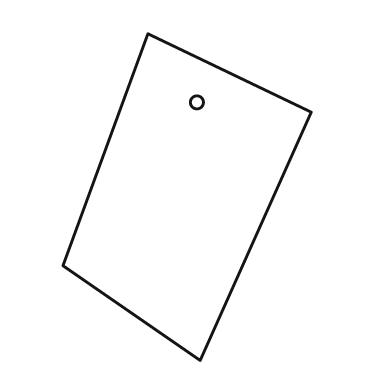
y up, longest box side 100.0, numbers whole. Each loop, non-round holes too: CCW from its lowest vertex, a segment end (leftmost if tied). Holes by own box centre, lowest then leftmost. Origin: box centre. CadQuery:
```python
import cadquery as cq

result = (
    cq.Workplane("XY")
    .moveTo(4.0, -50.0)
    .lineTo(38.0, 26.0)
    .lineTo(-12.0, 50.0)
    .lineTo(-38.0, -21.0)
    .close()
    .moveTo(3.0, 29.0)
    .circle(2.0)
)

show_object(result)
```